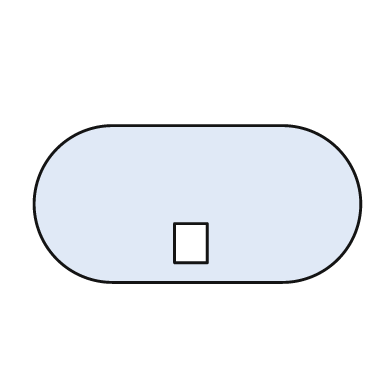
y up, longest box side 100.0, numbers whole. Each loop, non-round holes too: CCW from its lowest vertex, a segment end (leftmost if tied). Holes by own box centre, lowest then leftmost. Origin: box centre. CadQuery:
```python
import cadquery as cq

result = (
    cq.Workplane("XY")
    .moveTo(-26.0, -24.0)
    .lineTo(26.0, -24.0)
    .threePointArc((50.0, 0.0), (26.0, 24.0))
    .lineTo(-26.0, 24.0)
    .threePointArc((-50.0, 0.0), (-26.0, -24.0))
    .close()
    .moveTo(-7.0, -18.0)
    .lineTo(3.0, -18.0)
    .lineTo(3.0, -6.0)
    .lineTo(-7.0, -6.0)
    .close()
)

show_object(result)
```